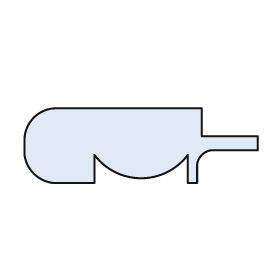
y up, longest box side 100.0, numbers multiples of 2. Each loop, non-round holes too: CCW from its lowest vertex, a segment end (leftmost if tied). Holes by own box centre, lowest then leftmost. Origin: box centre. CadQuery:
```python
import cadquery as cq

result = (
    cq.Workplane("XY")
    .moveTo(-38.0, -16.0)
    .lineTo(-20.0, -16.0)
    .lineTo(-20.0, -4.0)
    .threePointArc((0.0, -14.0), (20.0, -4.0))
    .lineTo(20.0, -16.0)
    .lineTo(24.0, -16.0)
    .lineTo(24.0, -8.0)
    .threePointArc((26.0, -4.0), (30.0, -2.0))
    .lineTo(50.0, -2.0)
    .lineTo(50.0, 4.0)
    .lineTo(26.0, 4.0)
    .lineTo(26.0, 16.0)
    .lineTo(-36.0, 16.0)
    .threePointArc((-46.0, 12.0), (-50.0, 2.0))
    .lineTo(-50.0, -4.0)
    .threePointArc((-46.0, -12.0), (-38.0, -16.0))
    .close()
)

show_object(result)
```